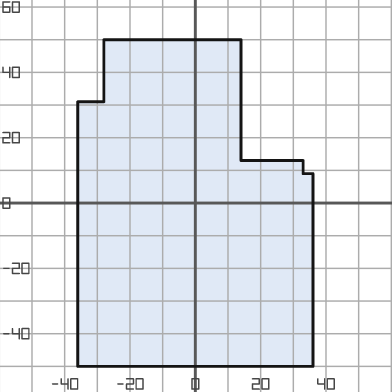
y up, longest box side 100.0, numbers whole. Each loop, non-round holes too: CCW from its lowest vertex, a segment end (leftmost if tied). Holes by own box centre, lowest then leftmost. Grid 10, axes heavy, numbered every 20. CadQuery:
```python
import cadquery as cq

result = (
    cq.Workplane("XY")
    .moveTo(-36.0, -50.0)
    .lineTo(36.0, -50.0)
    .lineTo(36.0, 9.0)
    .lineTo(33.0, 9.0)
    .lineTo(33.0, 13.0)
    .lineTo(14.0, 13.0)
    .lineTo(14.0, 50.0)
    .lineTo(-28.0, 50.0)
    .lineTo(-28.0, 31.0)
    .lineTo(-36.0, 31.0)
    .close()
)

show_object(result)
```